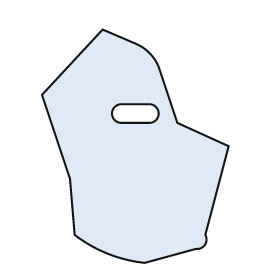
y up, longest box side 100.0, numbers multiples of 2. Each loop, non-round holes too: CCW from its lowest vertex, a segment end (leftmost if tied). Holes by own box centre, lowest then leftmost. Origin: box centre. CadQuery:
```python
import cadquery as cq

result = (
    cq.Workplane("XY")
    .moveTo(4.0, -50.0)
    .lineTo(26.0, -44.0)
    .threePointArc((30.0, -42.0), (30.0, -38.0))
    .lineTo(40.0, 0.0)
    .lineTo(18.0, 10.0)
    .lineTo(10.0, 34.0)
    .threePointArc((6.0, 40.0), (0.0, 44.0))
    .lineTo(-14.0, 50.0)
    .lineTo(-40.0, 22.0)
    .lineTo(-28.0, -14.0)
    .lineTo(-26.0, -38.0)
    .threePointArc((-12.0, -46.0), (4.0, -50.0))
    .close()
    .moveTo(-6.0, 10.0)
    .lineTo(6.0, 10.0)
    .threePointArc((10.0, 14.0), (6.0, 18.0))
    .lineTo(-6.0, 18.0)
    .threePointArc((-10.0, 14.0), (-6.0, 10.0))
    .close()
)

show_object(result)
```